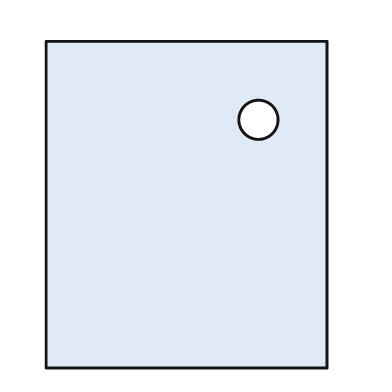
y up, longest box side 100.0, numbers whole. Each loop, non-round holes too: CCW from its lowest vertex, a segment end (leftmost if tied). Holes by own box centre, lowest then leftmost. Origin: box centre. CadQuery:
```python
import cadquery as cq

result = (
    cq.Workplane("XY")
    .moveTo(-43.0, -50.0)
    .lineTo(43.0, -50.0)
    .lineTo(43.0, 50.0)
    .lineTo(-43.0, 50.0)
    .close()
    .moveTo(22.0, 26.0)
    .circle(6.0)
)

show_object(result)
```